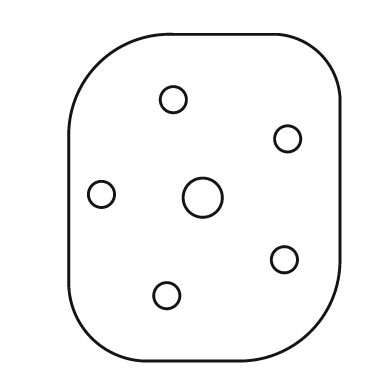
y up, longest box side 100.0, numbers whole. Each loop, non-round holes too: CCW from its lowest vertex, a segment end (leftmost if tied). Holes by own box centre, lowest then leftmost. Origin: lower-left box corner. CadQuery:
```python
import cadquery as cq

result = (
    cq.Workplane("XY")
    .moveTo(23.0, 0.0)
    .lineTo(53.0, 0.0)
    .threePointArc((74.0, 9.0), (83.0, 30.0))
    .lineTo(83.0, 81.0)
    .threePointArc((77.0, 94.0), (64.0, 100.0))
    .lineTo(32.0, 100.0)
    .threePointArc((9.0, 91.0), (0.0, 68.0))
    .lineTo(0.0, 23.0)
    .threePointArc((7.0, 7.0), (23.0, 0.0))
    .close()
    .moveTo(30.0, 20.0)
    .circle(4.0)
    .moveTo(66.0, 31.0)
    .circle(4.0)
    .moveTo(41.0, 50.0)
    .circle(6.0)
    .moveTo(10.0, 51.0)
    .circle(4.0)
    .moveTo(67.0, 68.0)
    .circle(4.0)
    .moveTo(32.0, 80.0)
    .circle(4.0)
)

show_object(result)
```